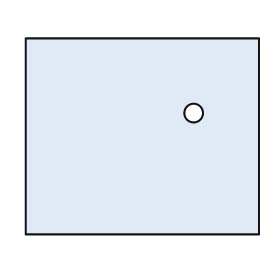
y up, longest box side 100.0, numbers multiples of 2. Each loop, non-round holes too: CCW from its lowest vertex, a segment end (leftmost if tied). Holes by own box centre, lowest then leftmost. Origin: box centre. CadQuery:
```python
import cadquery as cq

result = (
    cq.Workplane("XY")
    .moveTo(-50.0, -42.0)
    .lineTo(50.0, -42.0)
    .lineTo(50.0, 42.0)
    .lineTo(-50.0, 42.0)
    .close()
    .moveTo(22.0, 10.0)
    .circle(4.0)
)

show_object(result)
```